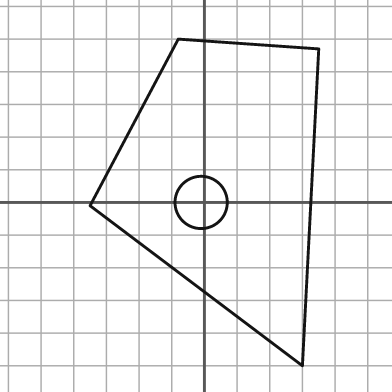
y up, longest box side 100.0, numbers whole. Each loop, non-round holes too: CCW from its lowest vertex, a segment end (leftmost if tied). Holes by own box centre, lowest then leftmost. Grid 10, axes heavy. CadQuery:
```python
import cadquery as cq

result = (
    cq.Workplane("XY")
    .moveTo(30.0, -50.0)
    .lineTo(35.0, 47.0)
    .lineTo(-8.0, 50.0)
    .lineTo(-35.0, -1.0)
    .close()
    .moveTo(-1.0, 0.0)
    .circle(8.0)
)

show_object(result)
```